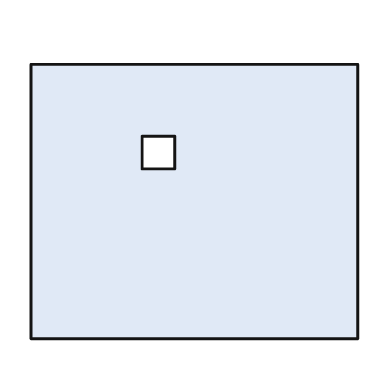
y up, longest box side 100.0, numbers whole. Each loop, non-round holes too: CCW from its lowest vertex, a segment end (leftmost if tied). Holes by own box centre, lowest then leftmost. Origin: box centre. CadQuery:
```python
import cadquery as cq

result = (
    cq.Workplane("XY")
    .moveTo(-50.0, -42.0)
    .lineTo(50.0, -42.0)
    .lineTo(50.0, 42.0)
    .lineTo(-50.0, 42.0)
    .close()
    .moveTo(-16.0, 10.0)
    .lineTo(-6.0, 10.0)
    .lineTo(-6.0, 20.0)
    .lineTo(-16.0, 20.0)
    .close()
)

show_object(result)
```